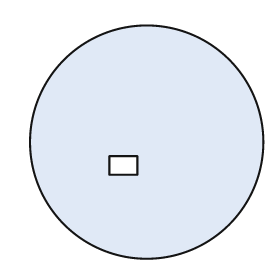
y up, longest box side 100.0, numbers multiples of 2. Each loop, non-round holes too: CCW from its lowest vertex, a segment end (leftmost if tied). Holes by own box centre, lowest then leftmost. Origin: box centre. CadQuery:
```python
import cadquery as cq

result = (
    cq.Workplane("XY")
    .moveTo(0.0, 0.0)
    .circle(50.0)
    .moveTo(-16.0, -14.0)
    .lineTo(-4.0, -14.0)
    .lineTo(-4.0, -6.0)
    .lineTo(-16.0, -6.0)
    .close()
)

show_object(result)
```